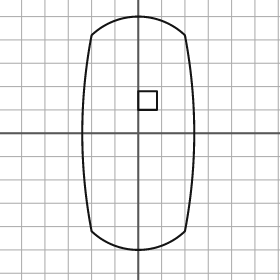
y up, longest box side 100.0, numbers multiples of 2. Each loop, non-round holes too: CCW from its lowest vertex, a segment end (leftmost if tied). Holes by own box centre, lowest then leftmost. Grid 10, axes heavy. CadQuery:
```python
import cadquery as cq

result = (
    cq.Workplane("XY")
    .moveTo(-20.0, -42.0)
    .threePointArc((0.0, -50.0), (20.0, -42.0))
    .threePointArc((24.0, 0.0), (20.0, 42.0))
    .threePointArc((0.0, 50.0), (-20.0, 42.0))
    .threePointArc((-24.0, 0.0), (-20.0, -42.0))
    .close()
    .moveTo(0.0, 10.0)
    .lineTo(8.0, 10.0)
    .lineTo(8.0, 18.0)
    .lineTo(0.0, 18.0)
    .close()
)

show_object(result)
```